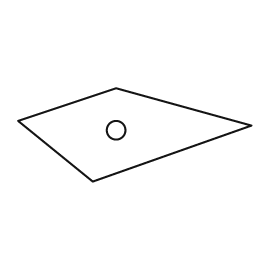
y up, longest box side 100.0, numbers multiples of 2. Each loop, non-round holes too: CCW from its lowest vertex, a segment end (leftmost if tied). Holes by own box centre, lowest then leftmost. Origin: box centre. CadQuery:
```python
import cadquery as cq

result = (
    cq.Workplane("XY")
    .moveTo(-18.0, -20.0)
    .lineTo(50.0, 4.0)
    .lineTo(-8.0, 20.0)
    .lineTo(-50.0, 6.0)
    .close()
    .moveTo(-8.0, 2.0)
    .circle(4.0)
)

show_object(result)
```